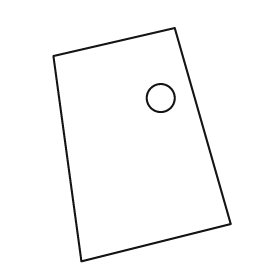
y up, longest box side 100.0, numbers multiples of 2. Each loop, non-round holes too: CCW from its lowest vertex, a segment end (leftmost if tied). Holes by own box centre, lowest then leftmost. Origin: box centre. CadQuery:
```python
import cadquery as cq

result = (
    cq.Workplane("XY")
    .moveTo(-26.0, -50.0)
    .lineTo(38.0, -34.0)
    .lineTo(14.0, 50.0)
    .lineTo(-38.0, 38.0)
    .close()
    .moveTo(8.0, 20.0)
    .circle(6.0)
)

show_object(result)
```